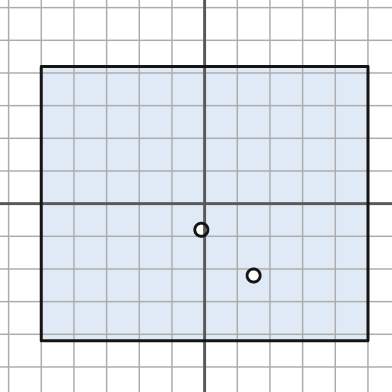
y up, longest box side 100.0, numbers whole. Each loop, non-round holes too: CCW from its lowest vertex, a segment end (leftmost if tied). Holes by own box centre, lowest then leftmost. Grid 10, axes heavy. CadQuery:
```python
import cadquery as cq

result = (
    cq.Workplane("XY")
    .moveTo(-50.0, -42.0)
    .lineTo(50.0, -42.0)
    .lineTo(50.0, 42.0)
    .lineTo(-50.0, 42.0)
    .close()
    .moveTo(15.0, -22.0)
    .circle(2.0)
    .moveTo(-1.0, -8.0)
    .circle(2.0)
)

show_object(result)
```